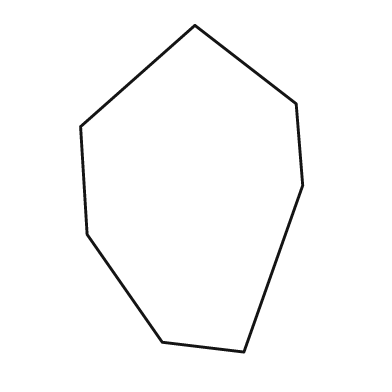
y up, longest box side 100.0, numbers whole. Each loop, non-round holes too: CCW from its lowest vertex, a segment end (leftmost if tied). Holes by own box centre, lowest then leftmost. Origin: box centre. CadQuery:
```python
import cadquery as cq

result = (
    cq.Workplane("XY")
    .moveTo(16.0, -50.0)
    .lineTo(34.0, 1.0)
    .lineTo(32.0, 26.0)
    .lineTo(1.0, 50.0)
    .lineTo(-34.0, 19.0)
    .lineTo(-32.0, -14.0)
    .lineTo(-9.0, -47.0)
    .close()
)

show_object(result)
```